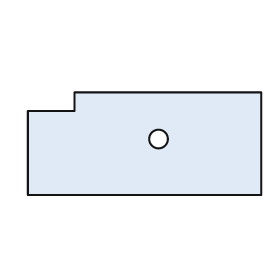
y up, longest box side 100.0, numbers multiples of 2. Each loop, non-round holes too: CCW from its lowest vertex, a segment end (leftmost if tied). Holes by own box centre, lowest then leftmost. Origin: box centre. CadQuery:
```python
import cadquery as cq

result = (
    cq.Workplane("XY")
    .moveTo(-50.0, -22.0)
    .lineTo(50.0, -22.0)
    .lineTo(50.0, 22.0)
    .lineTo(-30.0, 22.0)
    .lineTo(-30.0, 14.0)
    .lineTo(-50.0, 14.0)
    .close()
    .moveTo(6.0, 2.0)
    .circle(4.0)
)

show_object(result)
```